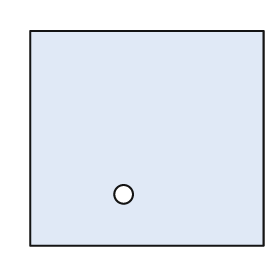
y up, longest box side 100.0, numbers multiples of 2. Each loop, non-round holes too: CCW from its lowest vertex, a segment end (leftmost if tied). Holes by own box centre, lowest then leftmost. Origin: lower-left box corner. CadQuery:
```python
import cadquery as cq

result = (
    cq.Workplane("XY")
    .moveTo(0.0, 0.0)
    .lineTo(100.0, 0.0)
    .lineTo(100.0, 92.0)
    .lineTo(0.0, 92.0)
    .close()
    .moveTo(40.0, 22.0)
    .circle(4.0)
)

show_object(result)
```